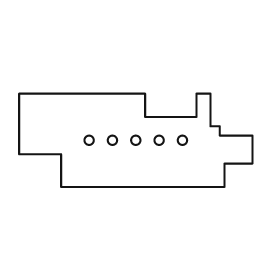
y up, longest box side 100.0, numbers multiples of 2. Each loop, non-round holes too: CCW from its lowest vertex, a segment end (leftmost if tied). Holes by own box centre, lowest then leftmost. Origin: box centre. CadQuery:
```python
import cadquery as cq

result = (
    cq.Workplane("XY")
    .moveTo(-32.0, -20.0)
    .lineTo(38.0, -20.0)
    .lineTo(38.0, -10.0)
    .lineTo(50.0, -10.0)
    .lineTo(50.0, 2.0)
    .lineTo(36.0, 2.0)
    .lineTo(36.0, 6.0)
    .lineTo(32.0, 6.0)
    .lineTo(32.0, 20.0)
    .lineTo(26.0, 20.0)
    .lineTo(26.0, 10.0)
    .lineTo(4.0, 10.0)
    .lineTo(4.0, 20.0)
    .lineTo(-50.0, 20.0)
    .lineTo(-50.0, -6.0)
    .lineTo(-32.0, -6.0)
    .close()
    .moveTo(-20.0, 0.0)
    .circle(2.0)
    .moveTo(-10.0, 0.0)
    .circle(2.0)
    .moveTo(0.0, 0.0)
    .circle(2.0)
    .moveTo(10.0, 0.0)
    .circle(2.0)
    .moveTo(20.0, 0.0)
    .circle(2.0)
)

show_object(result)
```